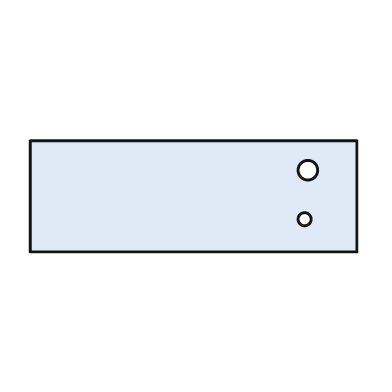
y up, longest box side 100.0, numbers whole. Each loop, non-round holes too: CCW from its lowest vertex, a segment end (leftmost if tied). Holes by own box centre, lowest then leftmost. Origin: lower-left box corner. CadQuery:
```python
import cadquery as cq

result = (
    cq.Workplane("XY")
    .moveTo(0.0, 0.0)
    .lineTo(100.0, 0.0)
    .lineTo(100.0, 34.0)
    .lineTo(0.0, 34.0)
    .close()
    .moveTo(84.0, 10.0)
    .circle(2.0)
    .moveTo(85.0, 25.0)
    .circle(3.0)
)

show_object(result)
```